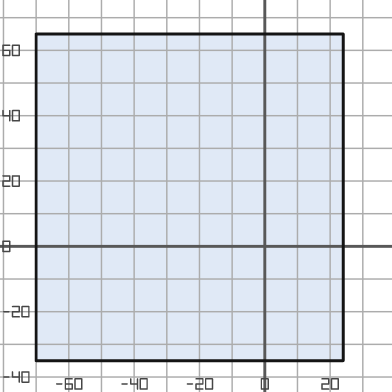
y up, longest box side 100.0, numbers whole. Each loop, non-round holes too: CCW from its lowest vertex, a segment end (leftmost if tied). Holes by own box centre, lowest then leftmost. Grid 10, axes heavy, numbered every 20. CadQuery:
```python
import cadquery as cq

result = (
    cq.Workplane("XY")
    .moveTo(-70.0, -35.0)
    .lineTo(24.0, -35.0)
    .lineTo(24.0, 65.0)
    .lineTo(-70.0, 65.0)
    .close()
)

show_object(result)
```